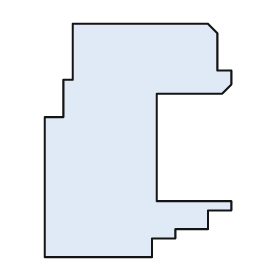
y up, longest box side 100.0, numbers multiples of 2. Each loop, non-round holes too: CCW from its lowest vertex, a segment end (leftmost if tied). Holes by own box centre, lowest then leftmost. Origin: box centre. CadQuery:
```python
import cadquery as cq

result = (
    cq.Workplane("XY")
    .moveTo(-40.0, -50.0)
    .lineTo(6.0, -50.0)
    .lineTo(6.0, -42.0)
    .lineTo(16.0, -42.0)
    .lineTo(16.0, -38.0)
    .lineTo(30.0, -38.0)
    .lineTo(30.0, -30.0)
    .lineTo(40.0, -30.0)
    .lineTo(40.0, -26.0)
    .lineTo(8.0, -26.0)
    .lineTo(8.0, 20.0)
    .lineTo(36.0, 20.0)
    .lineTo(40.0, 24.0)
    .lineTo(40.0, 30.0)
    .lineTo(34.0, 30.0)
    .lineTo(34.0, 46.0)
    .lineTo(30.0, 50.0)
    .lineTo(-28.0, 50.0)
    .lineTo(-28.0, 26.0)
    .lineTo(-32.0, 26.0)
    .lineTo(-32.0, 10.0)
    .lineTo(-40.0, 10.0)
    .close()
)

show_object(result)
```